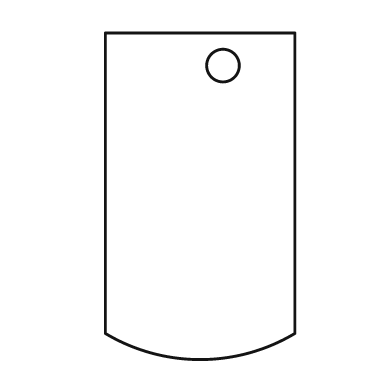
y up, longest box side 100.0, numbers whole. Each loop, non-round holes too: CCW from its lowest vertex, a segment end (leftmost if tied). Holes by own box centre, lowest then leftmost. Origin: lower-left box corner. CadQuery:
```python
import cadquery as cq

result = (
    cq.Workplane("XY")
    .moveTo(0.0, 8.0)
    .threePointArc((29.0, 0.0), (58.0, 8.0))
    .lineTo(58.0, 100.0)
    .lineTo(0.0, 100.0)
    .close()
    .moveTo(36.0, 90.0)
    .circle(5.0)
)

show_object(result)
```